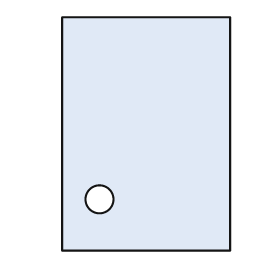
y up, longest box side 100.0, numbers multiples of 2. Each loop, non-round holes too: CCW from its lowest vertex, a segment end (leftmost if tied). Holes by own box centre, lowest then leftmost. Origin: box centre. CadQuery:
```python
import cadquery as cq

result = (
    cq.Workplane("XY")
    .moveTo(-36.0, -50.0)
    .lineTo(36.0, -50.0)
    .lineTo(36.0, 50.0)
    .lineTo(-36.0, 50.0)
    .close()
    .moveTo(-20.0, -28.0)
    .circle(6.0)
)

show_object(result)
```